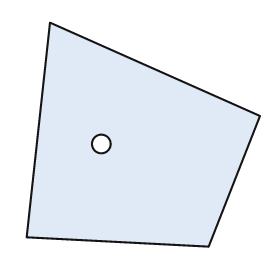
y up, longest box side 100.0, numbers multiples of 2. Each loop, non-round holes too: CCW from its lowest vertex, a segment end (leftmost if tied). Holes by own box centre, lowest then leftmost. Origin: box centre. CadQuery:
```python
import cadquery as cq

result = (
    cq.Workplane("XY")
    .moveTo(28.0, -48.0)
    .lineTo(50.0, 8.0)
    .lineTo(-40.0, 48.0)
    .lineTo(-50.0, -44.0)
    .close()
    .moveTo(-18.0, -4.0)
    .circle(4.0)
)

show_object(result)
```